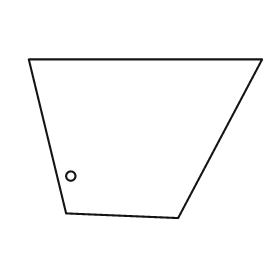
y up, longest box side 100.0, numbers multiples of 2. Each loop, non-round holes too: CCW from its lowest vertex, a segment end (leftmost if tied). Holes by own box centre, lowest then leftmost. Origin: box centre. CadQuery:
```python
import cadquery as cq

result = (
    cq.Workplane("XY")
    .moveTo(14.0, -34.0)
    .lineTo(50.0, 34.0)
    .lineTo(-50.0, 34.0)
    .lineTo(-34.0, -32.0)
    .close()
    .moveTo(-32.0, -16.0)
    .circle(2.0)
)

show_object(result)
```